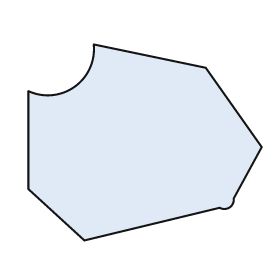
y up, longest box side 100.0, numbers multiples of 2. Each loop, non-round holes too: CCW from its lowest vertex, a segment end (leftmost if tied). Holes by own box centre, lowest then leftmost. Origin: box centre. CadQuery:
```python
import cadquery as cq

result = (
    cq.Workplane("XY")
    .moveTo(-26.0, -42.0)
    .lineTo(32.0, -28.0)
    .threePointArc((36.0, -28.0), (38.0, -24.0))
    .lineTo(50.0, -2.0)
    .lineTo(26.0, 32.0)
    .lineTo(-22.0, 42.0)
    .threePointArc((-30.0, 24.0), (-50.0, 22.0))
    .lineTo(-50.0, -20.0)
    .close()
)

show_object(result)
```